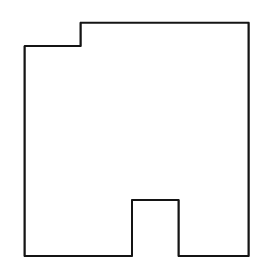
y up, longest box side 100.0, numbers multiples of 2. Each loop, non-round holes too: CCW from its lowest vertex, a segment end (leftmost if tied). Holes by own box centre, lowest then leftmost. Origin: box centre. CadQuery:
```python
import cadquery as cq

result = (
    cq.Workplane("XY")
    .moveTo(-48.0, -50.0)
    .lineTo(-2.0, -50.0)
    .lineTo(-2.0, -26.0)
    .lineTo(18.0, -26.0)
    .lineTo(18.0, -50.0)
    .lineTo(48.0, -50.0)
    .lineTo(48.0, 50.0)
    .lineTo(-24.0, 50.0)
    .lineTo(-24.0, 40.0)
    .lineTo(-48.0, 40.0)
    .close()
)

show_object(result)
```